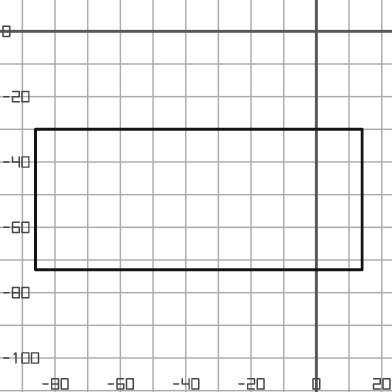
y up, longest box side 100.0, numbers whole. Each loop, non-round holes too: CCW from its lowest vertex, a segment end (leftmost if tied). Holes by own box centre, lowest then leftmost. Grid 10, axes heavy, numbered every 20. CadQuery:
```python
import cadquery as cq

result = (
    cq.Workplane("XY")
    .moveTo(-86.0, -73.0)
    .lineTo(14.0, -73.0)
    .lineTo(14.0, -30.0)
    .lineTo(-86.0, -30.0)
    .close()
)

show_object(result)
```